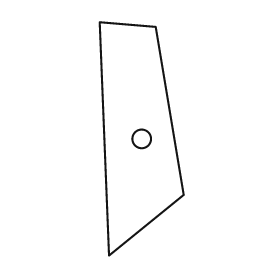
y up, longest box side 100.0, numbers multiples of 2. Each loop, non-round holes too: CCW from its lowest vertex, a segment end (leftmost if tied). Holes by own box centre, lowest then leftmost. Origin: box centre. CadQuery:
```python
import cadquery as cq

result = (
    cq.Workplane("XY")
    .moveTo(-14.0, -50.0)
    .lineTo(18.0, -24.0)
    .lineTo(6.0, 48.0)
    .lineTo(-18.0, 50.0)
    .close()
    .moveTo(0.0, 0.0)
    .circle(4.0)
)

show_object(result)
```